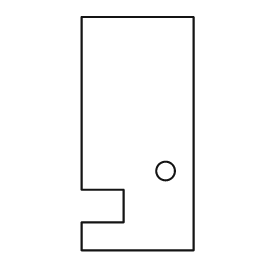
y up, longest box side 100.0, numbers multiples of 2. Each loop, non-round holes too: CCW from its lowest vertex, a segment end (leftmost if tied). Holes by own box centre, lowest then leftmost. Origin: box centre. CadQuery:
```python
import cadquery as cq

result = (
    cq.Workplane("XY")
    .moveTo(-24.0, -50.0)
    .lineTo(24.0, -50.0)
    .lineTo(24.0, 50.0)
    .lineTo(-24.0, 50.0)
    .lineTo(-24.0, -24.0)
    .lineTo(-6.0, -24.0)
    .lineTo(-6.0, -38.0)
    .lineTo(-24.0, -38.0)
    .close()
    .moveTo(12.0, -16.0)
    .circle(4.0)
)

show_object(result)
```